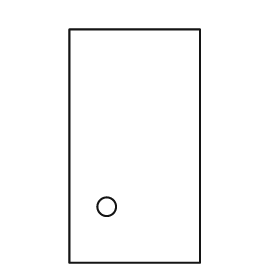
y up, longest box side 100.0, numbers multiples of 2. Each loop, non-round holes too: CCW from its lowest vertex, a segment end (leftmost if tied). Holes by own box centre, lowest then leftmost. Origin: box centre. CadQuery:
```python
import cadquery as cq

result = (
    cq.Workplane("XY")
    .moveTo(-28.0, -50.0)
    .lineTo(28.0, -50.0)
    .lineTo(28.0, 50.0)
    .lineTo(-28.0, 50.0)
    .close()
    .moveTo(-12.0, -26.0)
    .circle(4.0)
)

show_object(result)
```